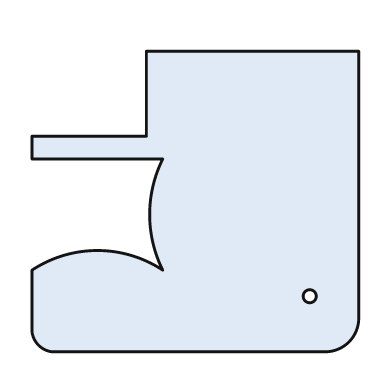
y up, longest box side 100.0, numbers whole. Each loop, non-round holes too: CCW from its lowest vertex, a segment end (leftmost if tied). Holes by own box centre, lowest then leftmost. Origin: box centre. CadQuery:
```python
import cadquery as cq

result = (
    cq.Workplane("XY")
    .moveTo(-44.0, -46.0)
    .lineTo(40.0, -46.0)
    .threePointArc((47.0, -43.0), (50.0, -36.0))
    .lineTo(50.0, 46.0)
    .lineTo(-15.0, 46.0)
    .lineTo(-15.0, 20.0)
    .lineTo(-50.0, 20.0)
    .lineTo(-50.0, 13.0)
    .lineTo(-10.0, 13.0)
    .threePointArc((-14.0, -4.0), (-10.0, -21.0))
    .threePointArc((-30.0, -15.0), (-50.0, -21.0))
    .lineTo(-50.0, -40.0)
    .threePointArc((-48.0, -44.0), (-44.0, -46.0))
    .close()
    .moveTo(35.0, -29.0)
    .circle(2.0)
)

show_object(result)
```